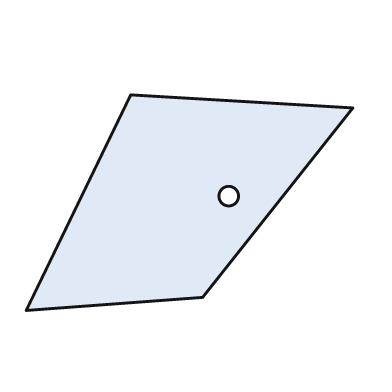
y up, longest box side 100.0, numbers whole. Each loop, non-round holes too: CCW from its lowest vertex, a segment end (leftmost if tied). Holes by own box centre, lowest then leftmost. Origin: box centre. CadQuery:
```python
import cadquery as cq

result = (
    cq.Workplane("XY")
    .moveTo(-50.0, -33.0)
    .lineTo(4.0, -29.0)
    .lineTo(50.0, 29.0)
    .lineTo(-18.0, 33.0)
    .close()
    .moveTo(12.0, 2.0)
    .circle(3.0)
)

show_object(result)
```